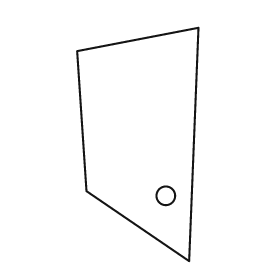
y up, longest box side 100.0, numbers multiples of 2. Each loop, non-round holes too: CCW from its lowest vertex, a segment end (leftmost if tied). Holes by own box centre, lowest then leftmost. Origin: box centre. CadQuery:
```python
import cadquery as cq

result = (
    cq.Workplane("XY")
    .moveTo(22.0, -50.0)
    .lineTo(26.0, 50.0)
    .lineTo(-26.0, 40.0)
    .lineTo(-22.0, -20.0)
    .close()
    .moveTo(12.0, -22.0)
    .circle(4.0)
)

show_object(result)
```